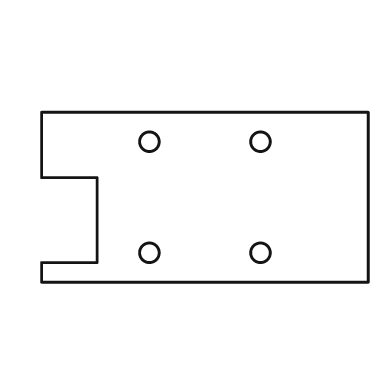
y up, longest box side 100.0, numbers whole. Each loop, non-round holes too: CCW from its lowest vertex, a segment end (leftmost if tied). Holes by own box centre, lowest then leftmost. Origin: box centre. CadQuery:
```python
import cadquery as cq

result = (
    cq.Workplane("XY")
    .moveTo(-50.0, -26.0)
    .lineTo(50.0, -26.0)
    .lineTo(50.0, 26.0)
    .lineTo(-50.0, 26.0)
    .lineTo(-50.0, 6.0)
    .lineTo(-33.0, 6.0)
    .lineTo(-33.0, -20.0)
    .lineTo(-50.0, -20.0)
    .close()
    .moveTo(-17.0, -17.0)
    .circle(3.0)
    .moveTo(17.0, -17.0)
    .circle(3.0)
    .moveTo(-17.0, 17.0)
    .circle(3.0)
    .moveTo(17.0, 17.0)
    .circle(3.0)
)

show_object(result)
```